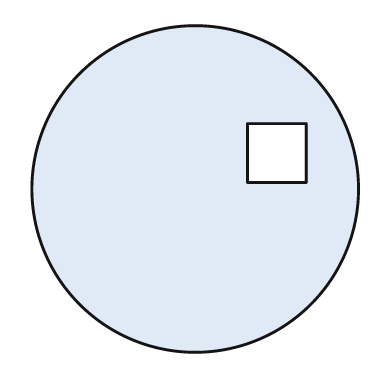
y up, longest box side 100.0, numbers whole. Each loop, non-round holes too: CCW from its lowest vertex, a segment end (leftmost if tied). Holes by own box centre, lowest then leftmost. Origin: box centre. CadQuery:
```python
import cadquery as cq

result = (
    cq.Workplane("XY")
    .moveTo(0.0, 0.0)
    .circle(50.0)
    .moveTo(16.0, 2.0)
    .lineTo(34.0, 2.0)
    .lineTo(34.0, 20.0)
    .lineTo(16.0, 20.0)
    .close()
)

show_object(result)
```